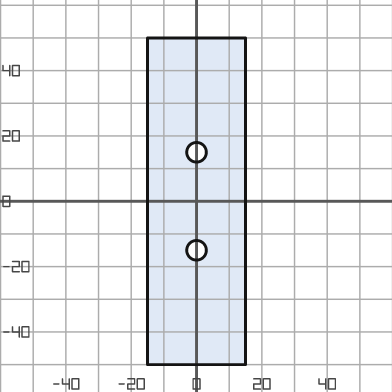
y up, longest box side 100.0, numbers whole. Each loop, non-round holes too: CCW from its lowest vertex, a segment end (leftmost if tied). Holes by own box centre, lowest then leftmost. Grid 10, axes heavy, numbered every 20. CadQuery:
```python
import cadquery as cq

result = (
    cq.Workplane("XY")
    .moveTo(-15.0, -50.0)
    .lineTo(15.0, -50.0)
    .lineTo(15.0, 50.0)
    .lineTo(-15.0, 50.0)
    .close()
    .moveTo(0.0, -15.0)
    .circle(3.0)
    .moveTo(0.0, 15.0)
    .circle(3.0)
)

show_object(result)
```